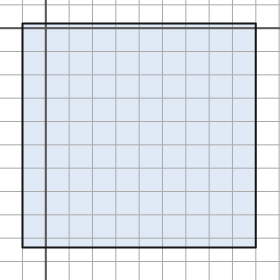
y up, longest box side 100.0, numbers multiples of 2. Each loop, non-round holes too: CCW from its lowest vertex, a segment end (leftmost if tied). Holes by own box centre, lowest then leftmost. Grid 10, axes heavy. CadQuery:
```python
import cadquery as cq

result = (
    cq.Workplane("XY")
    .moveTo(-10.0, -94.0)
    .lineTo(90.0, -94.0)
    .lineTo(90.0, 2.0)
    .lineTo(-10.0, 2.0)
    .close()
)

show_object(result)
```